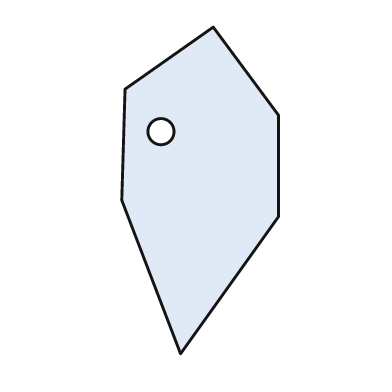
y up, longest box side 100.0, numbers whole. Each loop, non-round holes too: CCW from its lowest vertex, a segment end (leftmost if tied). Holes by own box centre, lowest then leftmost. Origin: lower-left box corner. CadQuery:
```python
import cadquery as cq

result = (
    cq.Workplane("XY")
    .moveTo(18.0, 0.0)
    .lineTo(48.0, 42.0)
    .lineTo(48.0, 73.0)
    .lineTo(28.0, 100.0)
    .lineTo(1.0, 81.0)
    .lineTo(0.0, 47.0)
    .close()
    .moveTo(12.0, 68.0)
    .circle(4.0)
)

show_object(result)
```